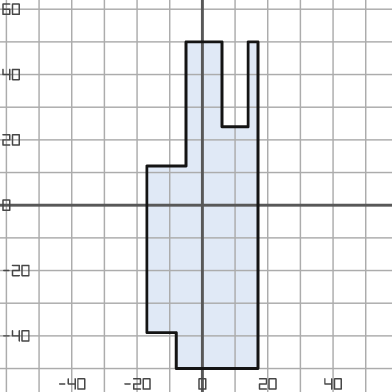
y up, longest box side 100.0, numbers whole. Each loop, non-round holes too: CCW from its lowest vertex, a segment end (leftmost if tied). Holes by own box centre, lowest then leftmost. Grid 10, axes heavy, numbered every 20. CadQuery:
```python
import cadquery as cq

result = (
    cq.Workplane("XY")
    .moveTo(-8.0, -50.0)
    .lineTo(17.0, -50.0)
    .lineTo(17.0, 50.0)
    .lineTo(14.0, 50.0)
    .lineTo(14.0, 24.0)
    .lineTo(6.0, 24.0)
    .lineTo(6.0, 50.0)
    .lineTo(-5.0, 50.0)
    .lineTo(-5.0, 12.0)
    .lineTo(-17.0, 12.0)
    .lineTo(-17.0, -39.0)
    .lineTo(-8.0, -39.0)
    .close()
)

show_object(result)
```